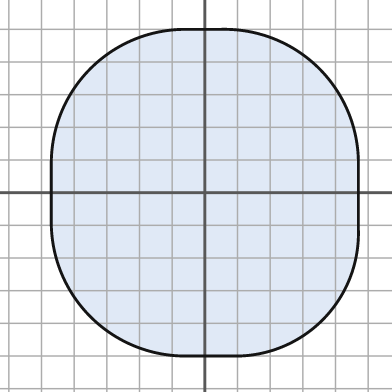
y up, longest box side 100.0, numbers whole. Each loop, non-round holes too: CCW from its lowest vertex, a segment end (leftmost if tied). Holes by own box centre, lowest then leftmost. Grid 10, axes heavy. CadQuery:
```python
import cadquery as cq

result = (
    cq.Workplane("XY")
    .moveTo(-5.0, -50.0)
    .lineTo(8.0, -50.0)
    .threePointArc((36.0, -39.0), (47.0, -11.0))
    .lineTo(47.0, 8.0)
    .threePointArc((35.0, 38.0), (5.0, 50.0))
    .lineTo(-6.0, 50.0)
    .threePointArc((-35.0, 38.0), (-47.0, 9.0))
    .lineTo(-47.0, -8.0)
    .threePointArc((-35.0, -38.0), (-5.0, -50.0))
    .close()
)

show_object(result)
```